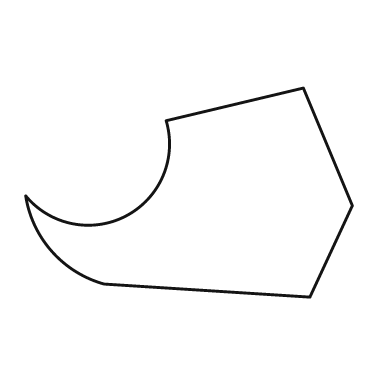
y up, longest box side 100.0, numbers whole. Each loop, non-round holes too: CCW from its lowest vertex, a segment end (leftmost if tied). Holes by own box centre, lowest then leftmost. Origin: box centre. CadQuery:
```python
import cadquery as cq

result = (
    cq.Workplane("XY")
    .moveTo(37.0, -32.0)
    .lineTo(50.0, -4.0)
    .lineTo(35.0, 32.0)
    .lineTo(-7.0, 22.0)
    .threePointArc((-19.0, -7.0), (-50.0, -1.0))
    .threePointArc((-42.0, -18.0), (-26.0, -28.0))
    .close()
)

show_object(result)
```